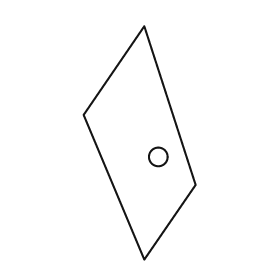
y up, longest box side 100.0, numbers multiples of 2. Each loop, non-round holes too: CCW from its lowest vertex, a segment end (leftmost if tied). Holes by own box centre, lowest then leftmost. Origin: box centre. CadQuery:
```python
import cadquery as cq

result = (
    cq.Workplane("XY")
    .moveTo(2.0, -50.0)
    .lineTo(24.0, -18.0)
    .lineTo(2.0, 50.0)
    .lineTo(-24.0, 12.0)
    .close()
    .moveTo(8.0, -6.0)
    .circle(4.0)
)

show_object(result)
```